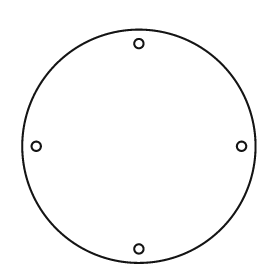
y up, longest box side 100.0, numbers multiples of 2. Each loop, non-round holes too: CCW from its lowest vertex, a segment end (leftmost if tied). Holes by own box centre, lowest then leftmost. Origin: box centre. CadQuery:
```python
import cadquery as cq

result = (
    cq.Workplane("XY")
    .moveTo(0.0, 0.0)
    .circle(50.0)
    .moveTo(0.0, -44.0)
    .circle(2.0)
    .moveTo(-44.0, 0.0)
    .circle(2.0)
    .moveTo(44.0, 0.0)
    .circle(2.0)
    .moveTo(0.0, 44.0)
    .circle(2.0)
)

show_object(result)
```